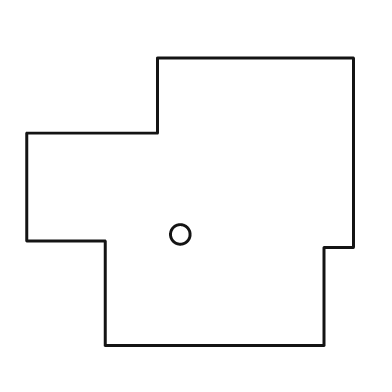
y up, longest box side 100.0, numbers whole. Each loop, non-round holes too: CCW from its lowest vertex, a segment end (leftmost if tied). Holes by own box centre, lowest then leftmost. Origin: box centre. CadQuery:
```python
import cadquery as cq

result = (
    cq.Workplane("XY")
    .moveTo(-26.0, -44.0)
    .lineTo(41.0, -44.0)
    .lineTo(41.0, -14.0)
    .lineTo(50.0, -14.0)
    .lineTo(50.0, 44.0)
    .lineTo(-10.0, 44.0)
    .lineTo(-10.0, 21.0)
    .lineTo(-50.0, 21.0)
    .lineTo(-50.0, -12.0)
    .lineTo(-26.0, -12.0)
    .close()
    .moveTo(-3.0, -10.0)
    .circle(3.0)
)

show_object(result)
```